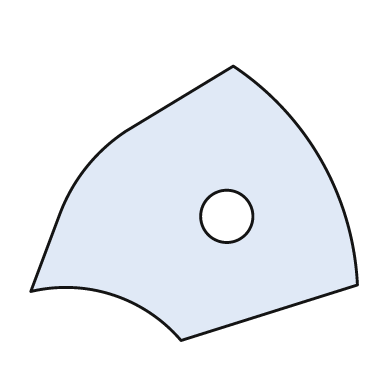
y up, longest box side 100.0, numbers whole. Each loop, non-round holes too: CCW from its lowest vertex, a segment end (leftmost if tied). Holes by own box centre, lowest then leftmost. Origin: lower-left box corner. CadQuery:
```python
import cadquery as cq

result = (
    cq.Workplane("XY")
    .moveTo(46.0, 0.0)
    .lineTo(100.0, 17.0)
    .threePointArc((89.0, 55.0), (62.0, 84.0))
    .lineTo(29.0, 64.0)
    .threePointArc((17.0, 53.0), (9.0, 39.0))
    .lineTo(0.0, 15.0)
    .threePointArc((25.0, 14.0), (46.0, 0.0))
    .close()
    .moveTo(60.0, 38.0)
    .circle(8.0)
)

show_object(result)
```